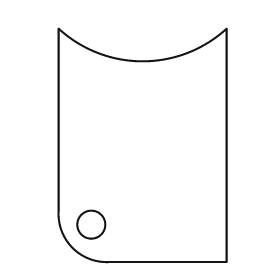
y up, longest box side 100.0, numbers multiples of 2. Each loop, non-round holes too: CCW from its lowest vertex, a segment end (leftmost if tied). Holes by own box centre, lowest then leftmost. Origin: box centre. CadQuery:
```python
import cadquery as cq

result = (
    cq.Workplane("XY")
    .moveTo(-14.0, -50.0)
    .lineTo(36.0, -50.0)
    .lineTo(36.0, 50.0)
    .threePointArc((0.0, 36.0), (-36.0, 50.0))
    .lineTo(-36.0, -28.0)
    .threePointArc((-30.0, -44.0), (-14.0, -50.0))
    .close()
    .moveTo(-22.0, -34.0)
    .circle(6.0)
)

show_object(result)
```